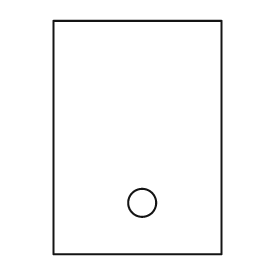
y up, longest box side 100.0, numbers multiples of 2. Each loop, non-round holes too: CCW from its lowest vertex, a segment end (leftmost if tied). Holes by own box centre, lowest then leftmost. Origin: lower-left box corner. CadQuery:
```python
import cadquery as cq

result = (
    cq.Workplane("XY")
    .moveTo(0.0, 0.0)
    .lineTo(72.0, 0.0)
    .lineTo(72.0, 100.0)
    .lineTo(0.0, 100.0)
    .close()
    .moveTo(38.0, 22.0)
    .circle(6.0)
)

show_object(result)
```